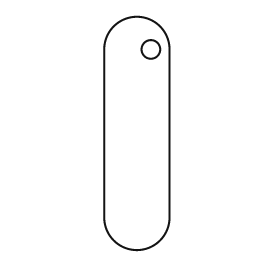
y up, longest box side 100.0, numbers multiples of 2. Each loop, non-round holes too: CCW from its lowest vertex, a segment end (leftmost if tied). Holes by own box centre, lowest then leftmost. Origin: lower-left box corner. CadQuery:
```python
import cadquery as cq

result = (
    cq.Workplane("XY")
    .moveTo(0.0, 14.0)
    .threePointArc((14.0, 0.0), (28.0, 14.0))
    .lineTo(28.0, 86.0)
    .threePointArc((14.0, 100.0), (0.0, 86.0))
    .close()
    .moveTo(20.0, 86.0)
    .circle(4.0)
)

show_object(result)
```